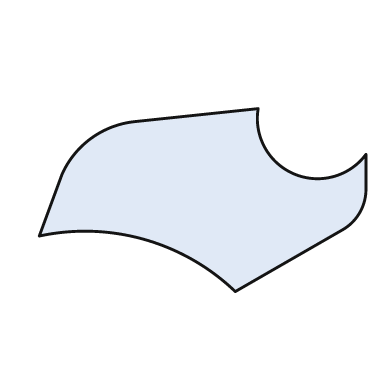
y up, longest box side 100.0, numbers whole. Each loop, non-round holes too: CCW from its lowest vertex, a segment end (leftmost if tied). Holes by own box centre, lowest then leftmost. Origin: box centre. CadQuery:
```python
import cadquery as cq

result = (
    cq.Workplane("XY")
    .moveTo(10.0, -28.0)
    .lineTo(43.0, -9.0)
    .threePointArc((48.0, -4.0), (50.0, 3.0))
    .lineTo(50.0, 14.0)
    .threePointArc((28.0, 8.0), (17.0, 28.0))
    .lineTo(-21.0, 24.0)
    .threePointArc((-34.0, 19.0), (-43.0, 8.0))
    .lineTo(-50.0, -11.0)
    .threePointArc((-18.0, -12.0), (10.0, -28.0))
    .close()
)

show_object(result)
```